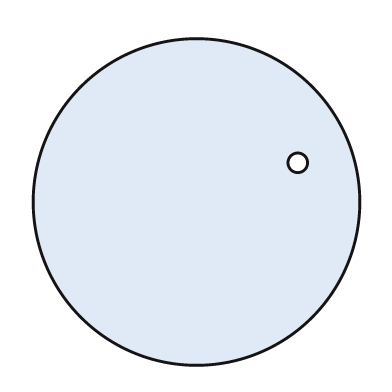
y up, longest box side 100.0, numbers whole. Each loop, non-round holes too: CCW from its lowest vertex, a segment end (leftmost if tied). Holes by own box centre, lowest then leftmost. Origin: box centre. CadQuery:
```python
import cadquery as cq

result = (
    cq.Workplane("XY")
    .moveTo(0.0, 0.0)
    .circle(50.0)
    .moveTo(31.0, 12.0)
    .circle(3.0)
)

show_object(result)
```